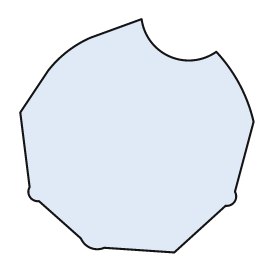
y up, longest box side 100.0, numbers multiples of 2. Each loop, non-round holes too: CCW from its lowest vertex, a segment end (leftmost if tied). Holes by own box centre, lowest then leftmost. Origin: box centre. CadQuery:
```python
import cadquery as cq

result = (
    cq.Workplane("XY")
    .moveTo(16.0, -50.0)
    .lineTo(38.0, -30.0)
    .threePointArc((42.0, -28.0), (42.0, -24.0))
    .lineTo(50.0, 6.0)
    .threePointArc((44.0, 22.0), (34.0, 36.0))
    .threePointArc((14.0, 34.0), (2.0, 50.0))
    .lineTo(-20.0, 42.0)
    .threePointArc((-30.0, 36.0), (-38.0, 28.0))
    .lineTo(-50.0, 10.0)
    .lineTo(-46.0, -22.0)
    .threePointArc((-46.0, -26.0), (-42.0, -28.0))
    .lineTo(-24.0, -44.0)
    .threePointArc((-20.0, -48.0), (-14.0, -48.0))
    .close()
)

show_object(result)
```